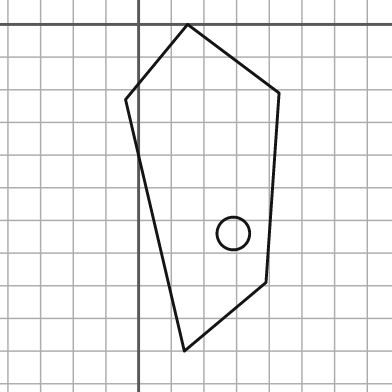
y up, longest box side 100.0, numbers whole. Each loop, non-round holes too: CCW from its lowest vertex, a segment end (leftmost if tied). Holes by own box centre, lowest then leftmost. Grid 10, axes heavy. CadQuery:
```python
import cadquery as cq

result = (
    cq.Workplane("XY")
    .moveTo(14.0, -100.0)
    .lineTo(39.0, -79.0)
    .lineTo(43.0, -21.0)
    .lineTo(15.0, 0.0)
    .lineTo(-4.0, -23.0)
    .close()
    .moveTo(29.0, -64.0)
    .circle(5.0)
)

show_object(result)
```